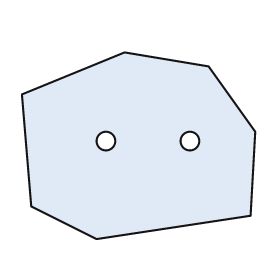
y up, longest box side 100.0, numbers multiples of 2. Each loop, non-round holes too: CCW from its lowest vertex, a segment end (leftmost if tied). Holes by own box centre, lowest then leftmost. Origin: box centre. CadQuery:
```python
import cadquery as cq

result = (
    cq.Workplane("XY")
    .moveTo(-18.0, -40.0)
    .lineTo(48.0, -30.0)
    .lineTo(50.0, 6.0)
    .lineTo(30.0, 34.0)
    .lineTo(-6.0, 40.0)
    .lineTo(-50.0, 22.0)
    .lineTo(-46.0, -26.0)
    .close()
    .moveTo(-14.0, 2.0)
    .circle(4.0)
    .moveTo(22.0, 2.0)
    .circle(4.0)
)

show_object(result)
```